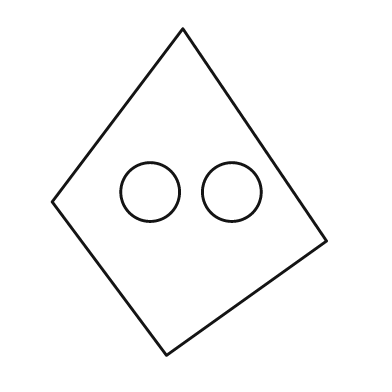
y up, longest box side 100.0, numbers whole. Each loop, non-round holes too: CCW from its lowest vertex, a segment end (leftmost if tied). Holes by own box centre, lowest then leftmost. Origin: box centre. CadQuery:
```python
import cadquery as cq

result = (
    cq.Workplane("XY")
    .moveTo(-7.0, -50.0)
    .lineTo(42.0, -15.0)
    .lineTo(-2.0, 50.0)
    .lineTo(-42.0, -3.0)
    .close()
    .moveTo(-12.0, 0.0)
    .circle(9.0)
    .moveTo(13.0, 0.0)
    .circle(9.0)
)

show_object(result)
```